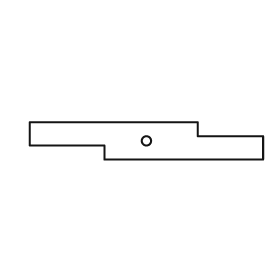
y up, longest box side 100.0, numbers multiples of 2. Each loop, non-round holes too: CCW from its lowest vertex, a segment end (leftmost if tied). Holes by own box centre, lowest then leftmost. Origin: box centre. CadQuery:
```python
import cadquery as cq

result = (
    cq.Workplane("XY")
    .moveTo(-18.0, -8.0)
    .lineTo(50.0, -8.0)
    .lineTo(50.0, 2.0)
    .lineTo(22.0, 2.0)
    .lineTo(22.0, 8.0)
    .lineTo(-50.0, 8.0)
    .lineTo(-50.0, -2.0)
    .lineTo(-18.0, -2.0)
    .close()
    .moveTo(0.0, 0.0)
    .circle(2.0)
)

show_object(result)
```